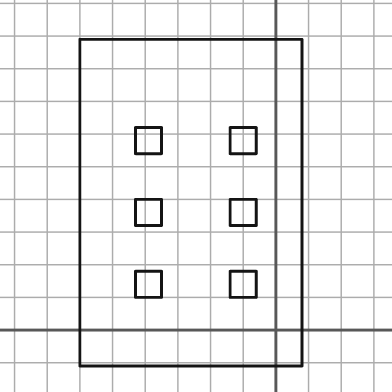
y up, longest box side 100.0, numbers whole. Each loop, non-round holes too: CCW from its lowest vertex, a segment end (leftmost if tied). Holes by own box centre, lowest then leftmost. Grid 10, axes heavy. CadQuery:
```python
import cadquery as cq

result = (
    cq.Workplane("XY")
    .moveTo(-60.0, -11.0)
    .lineTo(8.0, -11.0)
    .lineTo(8.0, 89.0)
    .lineTo(-60.0, 89.0)
    .close()
    .moveTo(-43.0, 10.0)
    .lineTo(-35.0, 10.0)
    .lineTo(-35.0, 18.0)
    .lineTo(-43.0, 18.0)
    .close()
    .moveTo(-14.0, 10.0)
    .lineTo(-6.0, 10.0)
    .lineTo(-6.0, 18.0)
    .lineTo(-14.0, 18.0)
    .close()
    .moveTo(-43.0, 32.0)
    .lineTo(-35.0, 32.0)
    .lineTo(-35.0, 40.0)
    .lineTo(-43.0, 40.0)
    .close()
    .moveTo(-14.0, 32.0)
    .lineTo(-6.0, 32.0)
    .lineTo(-6.0, 40.0)
    .lineTo(-14.0, 40.0)
    .close()
    .moveTo(-43.0, 54.0)
    .lineTo(-35.0, 54.0)
    .lineTo(-35.0, 62.0)
    .lineTo(-43.0, 62.0)
    .close()
    .moveTo(-14.0, 54.0)
    .lineTo(-6.0, 54.0)
    .lineTo(-6.0, 62.0)
    .lineTo(-14.0, 62.0)
    .close()
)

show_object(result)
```